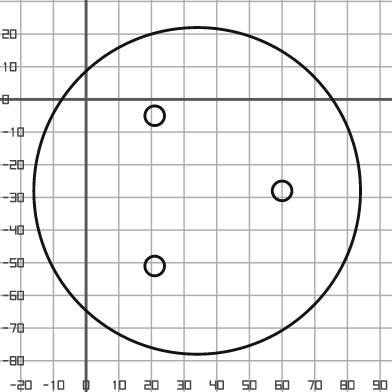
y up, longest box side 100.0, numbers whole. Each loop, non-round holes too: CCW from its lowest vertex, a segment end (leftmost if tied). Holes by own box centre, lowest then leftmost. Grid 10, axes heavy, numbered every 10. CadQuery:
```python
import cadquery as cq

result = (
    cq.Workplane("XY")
    .moveTo(34.0, -28.0)
    .circle(50.0)
    .moveTo(21.0, -51.0)
    .circle(3.0)
    .moveTo(60.0, -28.0)
    .circle(3.0)
    .moveTo(21.0, -5.0)
    .circle(3.0)
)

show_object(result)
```